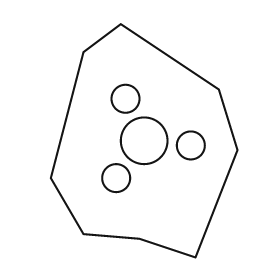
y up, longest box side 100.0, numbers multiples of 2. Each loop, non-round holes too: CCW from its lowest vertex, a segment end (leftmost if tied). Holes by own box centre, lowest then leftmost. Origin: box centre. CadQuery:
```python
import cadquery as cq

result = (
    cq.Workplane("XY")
    .moveTo(22.0, -50.0)
    .lineTo(40.0, -4.0)
    .lineTo(32.0, 22.0)
    .lineTo(-10.0, 50.0)
    .lineTo(-26.0, 38.0)
    .lineTo(-40.0, -16.0)
    .lineTo(-26.0, -40.0)
    .lineTo(-2.0, -42.0)
    .close()
    .moveTo(-12.0, -16.0)
    .circle(6.0)
    .moveTo(20.0, -2.0)
    .circle(6.0)
    .moveTo(0.0, 0.0)
    .circle(10.0)
    .moveTo(-8.0, 18.0)
    .circle(6.0)
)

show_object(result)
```